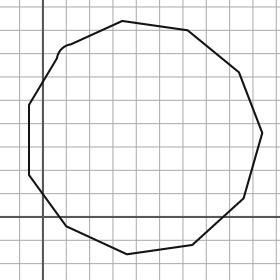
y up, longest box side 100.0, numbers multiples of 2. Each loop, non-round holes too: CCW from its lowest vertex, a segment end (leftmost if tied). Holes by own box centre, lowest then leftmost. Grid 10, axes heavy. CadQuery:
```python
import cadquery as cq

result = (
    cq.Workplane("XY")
    .moveTo(36.0, -16.0)
    .lineTo(64.0, -12.0)
    .lineTo(86.0, 8.0)
    .lineTo(94.0, 36.0)
    .lineTo(84.0, 62.0)
    .lineTo(62.0, 80.0)
    .lineTo(34.0, 84.0)
    .lineTo(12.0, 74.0)
    .threePointArc((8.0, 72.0), (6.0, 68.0))
    .lineTo(-6.0, 48.0)
    .lineTo(-6.0, 18.0)
    .lineTo(10.0, -4.0)
    .close()
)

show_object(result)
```